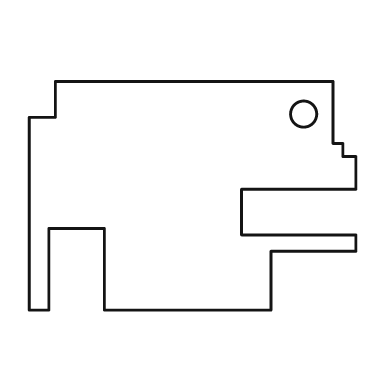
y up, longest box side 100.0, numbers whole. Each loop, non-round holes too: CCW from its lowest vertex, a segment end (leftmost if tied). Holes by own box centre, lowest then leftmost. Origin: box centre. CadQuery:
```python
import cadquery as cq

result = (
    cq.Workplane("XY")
    .moveTo(-50.0, -35.0)
    .lineTo(-44.0, -35.0)
    .lineTo(-44.0, -10.0)
    .lineTo(-27.0, -10.0)
    .lineTo(-27.0, -35.0)
    .lineTo(24.0, -35.0)
    .lineTo(24.0, -17.0)
    .lineTo(50.0, -17.0)
    .lineTo(50.0, -12.0)
    .lineTo(15.0, -12.0)
    .lineTo(15.0, 2.0)
    .lineTo(50.0, 2.0)
    .lineTo(50.0, 12.0)
    .lineTo(46.0, 12.0)
    .lineTo(46.0, 16.0)
    .lineTo(43.0, 16.0)
    .lineTo(43.0, 35.0)
    .lineTo(-42.0, 35.0)
    .lineTo(-42.0, 24.0)
    .lineTo(-50.0, 24.0)
    .close()
    .moveTo(34.0, 25.0)
    .circle(4.0)
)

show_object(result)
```